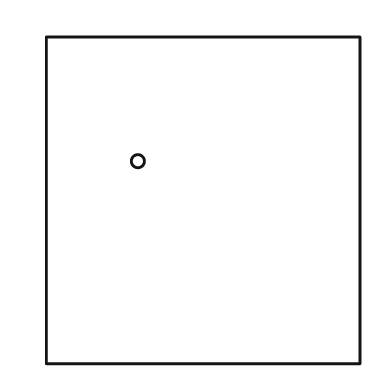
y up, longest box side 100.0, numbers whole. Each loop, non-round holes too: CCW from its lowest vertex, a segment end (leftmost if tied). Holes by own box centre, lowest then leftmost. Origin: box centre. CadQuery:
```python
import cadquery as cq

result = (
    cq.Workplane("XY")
    .moveTo(-48.0, -50.0)
    .lineTo(48.0, -50.0)
    .lineTo(48.0, 50.0)
    .lineTo(-48.0, 50.0)
    .close()
    .moveTo(-20.0, 12.0)
    .circle(2.0)
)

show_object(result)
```